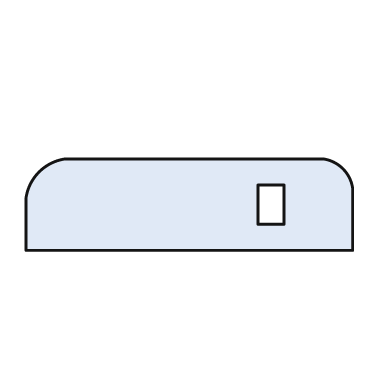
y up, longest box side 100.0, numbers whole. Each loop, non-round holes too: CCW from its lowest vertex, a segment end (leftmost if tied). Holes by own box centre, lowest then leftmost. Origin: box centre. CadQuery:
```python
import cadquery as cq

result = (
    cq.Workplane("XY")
    .moveTo(-50.0, -14.0)
    .lineTo(50.0, -14.0)
    .lineTo(50.0, 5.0)
    .threePointArc((47.0, 11.0), (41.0, 14.0))
    .lineTo(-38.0, 14.0)
    .threePointArc((-46.0, 10.0), (-50.0, 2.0))
    .close()
    .moveTo(21.0, -6.0)
    .lineTo(29.0, -6.0)
    .lineTo(29.0, 6.0)
    .lineTo(21.0, 6.0)
    .close()
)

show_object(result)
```